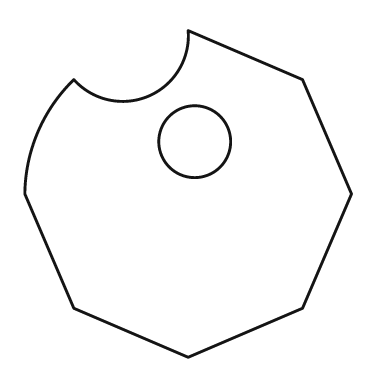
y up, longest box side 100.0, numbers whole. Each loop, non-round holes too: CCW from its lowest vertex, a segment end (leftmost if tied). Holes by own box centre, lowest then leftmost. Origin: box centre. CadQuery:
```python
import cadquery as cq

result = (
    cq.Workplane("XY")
    .moveTo(0.0, -50.0)
    .lineTo(35.0, -35.0)
    .lineTo(50.0, 0.0)
    .lineTo(35.0, 35.0)
    .lineTo(0.0, 50.0)
    .threePointArc((-12.0, 30.0), (-35.0, 35.0))
    .threePointArc((-46.0, 19.0), (-50.0, 0.0))
    .lineTo(-35.0, -35.0)
    .close()
    .moveTo(2.0, 16.0)
    .circle(11.0)
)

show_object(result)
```